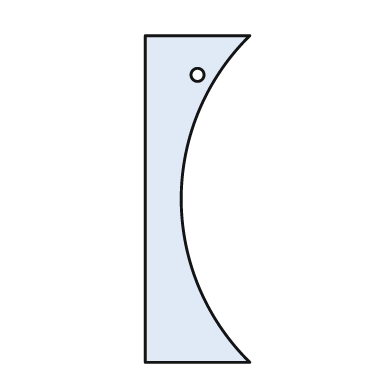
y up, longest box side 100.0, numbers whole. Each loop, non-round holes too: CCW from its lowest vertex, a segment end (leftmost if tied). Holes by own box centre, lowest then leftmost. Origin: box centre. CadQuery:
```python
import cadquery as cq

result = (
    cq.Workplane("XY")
    .moveTo(-16.0, -50.0)
    .lineTo(16.0, -50.0)
    .threePointArc((-5.0, 0.0), (16.0, 50.0))
    .lineTo(-16.0, 50.0)
    .close()
    .moveTo(0.0, 38.0)
    .circle(2.0)
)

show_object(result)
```